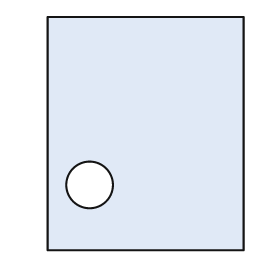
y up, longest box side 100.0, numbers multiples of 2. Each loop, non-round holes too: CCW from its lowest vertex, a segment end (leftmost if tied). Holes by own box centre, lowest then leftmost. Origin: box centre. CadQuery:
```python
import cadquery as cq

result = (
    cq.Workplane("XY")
    .moveTo(-42.0, -50.0)
    .lineTo(42.0, -50.0)
    .lineTo(42.0, 50.0)
    .lineTo(-42.0, 50.0)
    .close()
    .moveTo(-24.0, -22.0)
    .circle(10.0)
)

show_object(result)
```